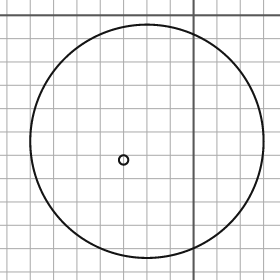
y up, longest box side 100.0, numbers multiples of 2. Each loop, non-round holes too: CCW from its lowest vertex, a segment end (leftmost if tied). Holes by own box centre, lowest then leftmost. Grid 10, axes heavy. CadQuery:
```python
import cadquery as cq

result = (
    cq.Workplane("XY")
    .moveTo(-20.0, -54.0)
    .circle(50.0)
    .moveTo(-30.0, -62.0)
    .circle(2.0)
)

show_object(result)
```